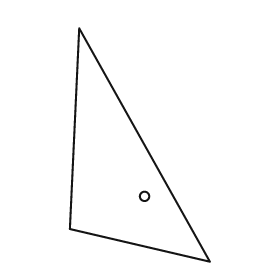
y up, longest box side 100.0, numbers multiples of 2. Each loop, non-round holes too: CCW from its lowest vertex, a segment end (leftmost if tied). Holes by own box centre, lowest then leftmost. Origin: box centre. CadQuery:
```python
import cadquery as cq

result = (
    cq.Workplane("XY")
    .moveTo(30.0, -50.0)
    .lineTo(-26.0, 50.0)
    .lineTo(-30.0, -36.0)
    .close()
    .moveTo(2.0, -22.0)
    .circle(2.0)
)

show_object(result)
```